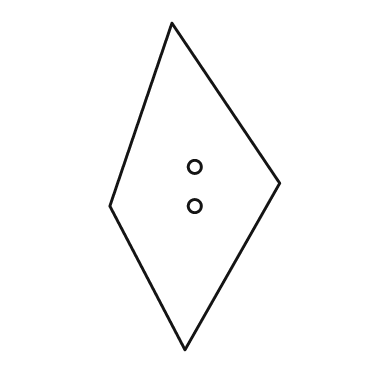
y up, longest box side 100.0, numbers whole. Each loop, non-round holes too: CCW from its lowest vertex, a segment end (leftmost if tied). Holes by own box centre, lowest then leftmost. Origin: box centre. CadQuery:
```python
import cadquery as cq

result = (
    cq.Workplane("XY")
    .moveTo(-3.0, -50.0)
    .lineTo(26.0, 1.0)
    .lineTo(-7.0, 50.0)
    .lineTo(-26.0, -6.0)
    .close()
    .moveTo(0.0, -6.0)
    .circle(2.0)
    .moveTo(0.0, 6.0)
    .circle(2.0)
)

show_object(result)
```